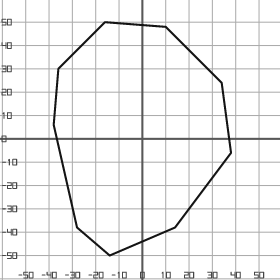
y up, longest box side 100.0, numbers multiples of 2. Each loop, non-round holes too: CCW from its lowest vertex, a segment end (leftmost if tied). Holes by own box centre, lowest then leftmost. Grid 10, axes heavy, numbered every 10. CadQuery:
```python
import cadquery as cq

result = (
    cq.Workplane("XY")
    .moveTo(-14.0, -50.0)
    .lineTo(14.0, -38.0)
    .lineTo(38.0, -6.0)
    .lineTo(34.0, 24.0)
    .lineTo(10.0, 48.0)
    .lineTo(-16.0, 50.0)
    .lineTo(-36.0, 30.0)
    .lineTo(-38.0, 6.0)
    .lineTo(-28.0, -38.0)
    .close()
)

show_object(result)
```